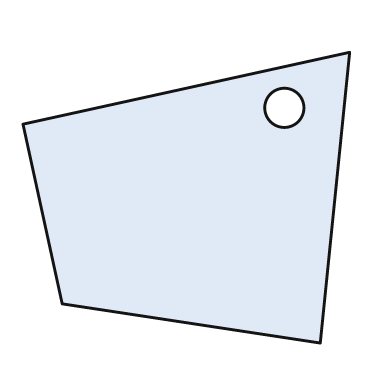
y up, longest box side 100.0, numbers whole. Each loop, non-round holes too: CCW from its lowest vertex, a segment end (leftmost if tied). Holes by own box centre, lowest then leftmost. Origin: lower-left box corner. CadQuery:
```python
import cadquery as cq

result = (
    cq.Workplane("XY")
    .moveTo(91.0, 0.0)
    .lineTo(100.0, 89.0)
    .lineTo(0.0, 67.0)
    .lineTo(12.0, 12.0)
    .close()
    .moveTo(80.0, 72.0)
    .circle(6.0)
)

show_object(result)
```